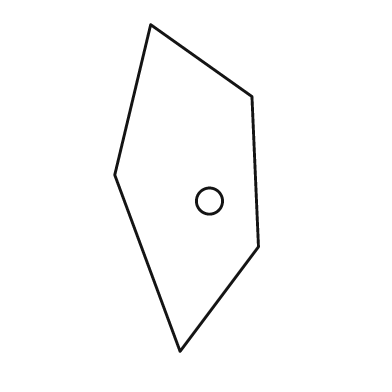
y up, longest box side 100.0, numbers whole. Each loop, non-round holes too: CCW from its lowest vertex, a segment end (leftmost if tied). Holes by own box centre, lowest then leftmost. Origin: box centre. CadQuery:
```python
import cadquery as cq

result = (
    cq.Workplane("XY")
    .moveTo(-2.0, -50.0)
    .lineTo(22.0, -18.0)
    .lineTo(20.0, 28.0)
    .lineTo(-11.0, 50.0)
    .lineTo(-22.0, 4.0)
    .close()
    .moveTo(7.0, -4.0)
    .circle(4.0)
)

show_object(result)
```